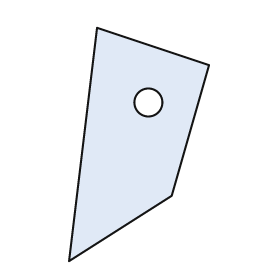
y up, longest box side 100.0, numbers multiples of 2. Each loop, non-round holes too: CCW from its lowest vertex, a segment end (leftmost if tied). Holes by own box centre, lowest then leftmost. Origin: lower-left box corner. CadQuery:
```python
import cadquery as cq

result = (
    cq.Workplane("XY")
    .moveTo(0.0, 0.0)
    .lineTo(44.0, 28.0)
    .lineTo(60.0, 84.0)
    .lineTo(12.0, 100.0)
    .close()
    .moveTo(34.0, 68.0)
    .circle(6.0)
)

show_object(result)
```